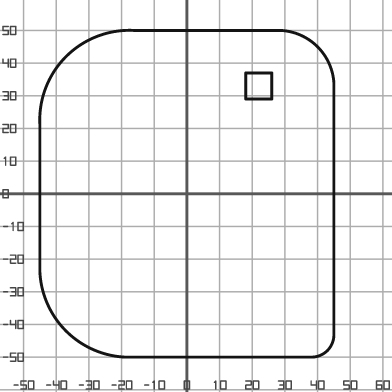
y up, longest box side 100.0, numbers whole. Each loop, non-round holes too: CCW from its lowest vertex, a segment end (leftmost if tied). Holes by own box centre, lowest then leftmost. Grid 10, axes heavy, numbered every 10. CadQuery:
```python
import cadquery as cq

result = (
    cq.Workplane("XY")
    .moveTo(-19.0, -50.0)
    .lineTo(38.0, -50.0)
    .threePointArc((43.0, -48.0), (45.0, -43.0))
    .lineTo(45.0, 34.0)
    .threePointArc((40.0, 45.0), (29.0, 50.0))
    .lineTo(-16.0, 50.0)
    .threePointArc((-37.0, 42.0), (-45.0, 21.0))
    .lineTo(-45.0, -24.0)
    .threePointArc((-37.0, -42.0), (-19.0, -50.0))
    .close()
    .moveTo(18.0, 29.0)
    .lineTo(26.0, 29.0)
    .lineTo(26.0, 37.0)
    .lineTo(18.0, 37.0)
    .close()
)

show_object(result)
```